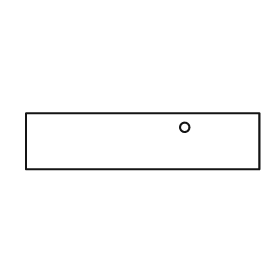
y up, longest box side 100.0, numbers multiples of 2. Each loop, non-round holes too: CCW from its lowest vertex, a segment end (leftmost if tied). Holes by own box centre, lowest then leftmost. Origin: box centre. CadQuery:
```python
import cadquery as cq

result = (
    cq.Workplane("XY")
    .moveTo(-50.0, -12.0)
    .lineTo(50.0, -12.0)
    .lineTo(50.0, 12.0)
    .lineTo(-50.0, 12.0)
    .close()
    .moveTo(18.0, 6.0)
    .circle(2.0)
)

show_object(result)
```